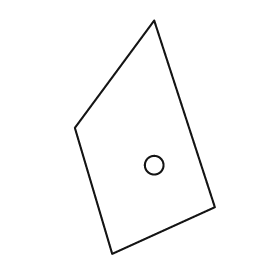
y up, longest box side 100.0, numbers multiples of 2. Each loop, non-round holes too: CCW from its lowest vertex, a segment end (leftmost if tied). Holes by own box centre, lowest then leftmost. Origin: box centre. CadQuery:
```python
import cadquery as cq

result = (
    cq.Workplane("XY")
    .moveTo(-14.0, -50.0)
    .lineTo(30.0, -30.0)
    .lineTo(4.0, 50.0)
    .lineTo(-30.0, 4.0)
    .close()
    .moveTo(4.0, -12.0)
    .circle(4.0)
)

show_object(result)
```